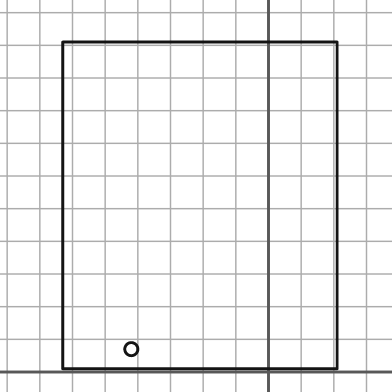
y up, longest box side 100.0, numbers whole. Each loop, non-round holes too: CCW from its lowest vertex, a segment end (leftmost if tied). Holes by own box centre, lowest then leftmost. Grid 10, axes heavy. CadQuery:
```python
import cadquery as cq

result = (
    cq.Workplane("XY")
    .moveTo(-63.0, 1.0)
    .lineTo(21.0, 1.0)
    .lineTo(21.0, 101.0)
    .lineTo(-63.0, 101.0)
    .close()
    .moveTo(-42.0, 7.0)
    .circle(2.0)
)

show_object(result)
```